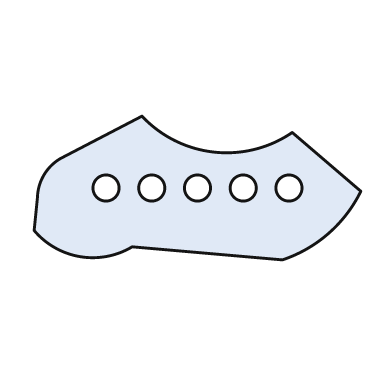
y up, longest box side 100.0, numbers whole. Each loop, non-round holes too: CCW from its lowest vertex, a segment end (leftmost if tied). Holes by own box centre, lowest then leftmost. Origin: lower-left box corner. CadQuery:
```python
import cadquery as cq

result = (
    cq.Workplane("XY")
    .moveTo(76.0, 0.0)
    .threePointArc((90.0, 8.0), (100.0, 21.0))
    .lineTo(79.0, 39.0)
    .threePointArc((55.0, 33.0), (33.0, 44.0))
    .lineTo(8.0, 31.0)
    .threePointArc((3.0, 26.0), (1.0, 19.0))
    .lineTo(0.0, 9.0)
    .threePointArc((14.0, 1.0), (30.0, 4.0))
    .close()
    .moveTo(22.0, 22.0)
    .circle(4.0)
    .moveTo(36.0, 22.0)
    .circle(4.0)
    .moveTo(50.0, 22.0)
    .circle(4.0)
    .moveTo(64.0, 22.0)
    .circle(4.0)
    .moveTo(78.0, 22.0)
    .circle(4.0)
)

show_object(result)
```